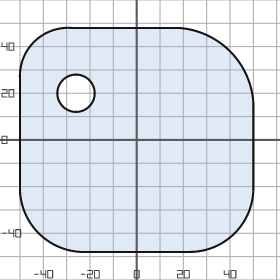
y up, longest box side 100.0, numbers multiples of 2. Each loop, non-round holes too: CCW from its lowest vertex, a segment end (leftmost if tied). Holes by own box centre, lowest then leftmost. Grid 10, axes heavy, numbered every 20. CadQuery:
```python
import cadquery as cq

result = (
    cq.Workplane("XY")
    .moveTo(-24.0, -48.0)
    .lineTo(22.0, -48.0)
    .threePointArc((42.0, -40.0), (50.0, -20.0))
    .lineTo(50.0, 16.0)
    .threePointArc((40.0, 38.0), (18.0, 48.0))
    .lineTo(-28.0, 48.0)
    .threePointArc((-44.0, 42.0), (-50.0, 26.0))
    .lineTo(-50.0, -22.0)
    .threePointArc((-42.0, -40.0), (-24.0, -48.0))
    .close()
    .moveTo(-26.0, 20.0)
    .circle(8.0)
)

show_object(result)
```